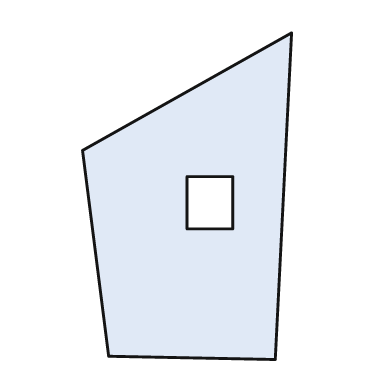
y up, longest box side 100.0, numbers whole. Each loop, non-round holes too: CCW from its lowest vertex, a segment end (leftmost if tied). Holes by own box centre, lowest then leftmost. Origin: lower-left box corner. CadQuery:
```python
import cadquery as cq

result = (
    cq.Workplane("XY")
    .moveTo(59.0, 0.0)
    .lineTo(64.0, 100.0)
    .lineTo(0.0, 64.0)
    .lineTo(8.0, 1.0)
    .close()
    .moveTo(32.0, 40.0)
    .lineTo(46.0, 40.0)
    .lineTo(46.0, 56.0)
    .lineTo(32.0, 56.0)
    .close()
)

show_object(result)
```